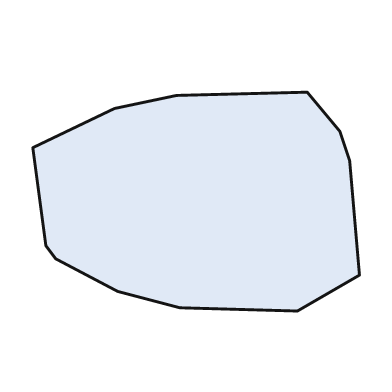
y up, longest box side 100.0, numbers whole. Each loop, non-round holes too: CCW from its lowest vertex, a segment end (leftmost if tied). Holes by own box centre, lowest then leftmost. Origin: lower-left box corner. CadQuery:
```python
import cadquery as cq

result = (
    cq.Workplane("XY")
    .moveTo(81.0, 0.0)
    .lineTo(100.0, 11.0)
    .lineTo(97.0, 46.0)
    .lineTo(94.0, 55.0)
    .lineTo(84.0, 67.0)
    .lineTo(44.0, 66.0)
    .lineTo(25.0, 62.0)
    .lineTo(0.0, 50.0)
    .lineTo(4.0, 20.0)
    .lineTo(7.0, 16.0)
    .lineTo(26.0, 6.0)
    .lineTo(45.0, 1.0)
    .close()
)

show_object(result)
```